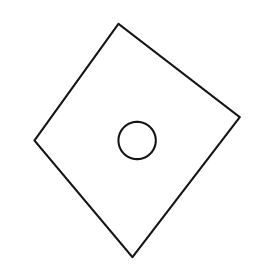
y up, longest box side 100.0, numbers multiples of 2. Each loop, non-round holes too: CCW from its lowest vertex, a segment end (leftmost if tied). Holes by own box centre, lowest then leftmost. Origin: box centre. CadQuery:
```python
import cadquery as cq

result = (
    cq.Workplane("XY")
    .moveTo(-2.0, -50.0)
    .lineTo(44.0, 10.0)
    .lineTo(-8.0, 50.0)
    .lineTo(-44.0, 0.0)
    .close()
    .moveTo(0.0, 0.0)
    .circle(8.0)
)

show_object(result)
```